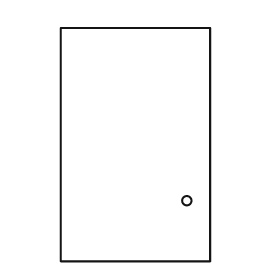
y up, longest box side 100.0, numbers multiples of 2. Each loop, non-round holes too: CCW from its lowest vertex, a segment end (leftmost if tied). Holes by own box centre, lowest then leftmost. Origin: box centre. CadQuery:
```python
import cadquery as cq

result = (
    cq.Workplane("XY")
    .moveTo(-32.0, -50.0)
    .lineTo(32.0, -50.0)
    .lineTo(32.0, 50.0)
    .lineTo(-32.0, 50.0)
    .close()
    .moveTo(22.0, -24.0)
    .circle(2.0)
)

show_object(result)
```